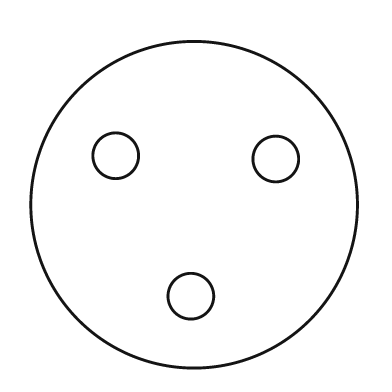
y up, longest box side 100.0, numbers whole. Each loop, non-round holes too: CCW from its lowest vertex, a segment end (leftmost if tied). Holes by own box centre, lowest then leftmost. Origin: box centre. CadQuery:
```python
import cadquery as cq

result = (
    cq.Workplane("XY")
    .moveTo(0.0, 0.0)
    .circle(50.0)
    .moveTo(-1.0, -28.0)
    .circle(7.0)
    .moveTo(25.0, 14.0)
    .circle(7.0)
    .moveTo(-24.0, 15.0)
    .circle(7.0)
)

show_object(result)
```